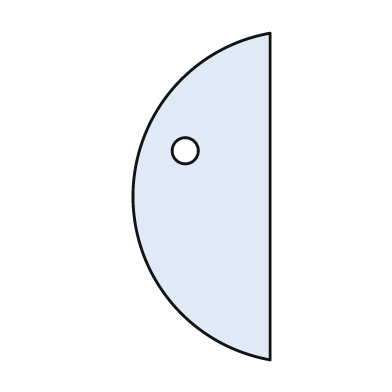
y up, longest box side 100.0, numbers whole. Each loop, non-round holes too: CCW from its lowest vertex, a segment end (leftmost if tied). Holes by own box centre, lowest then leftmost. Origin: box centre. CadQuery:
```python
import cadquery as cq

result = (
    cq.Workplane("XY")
    .moveTo(21.0, -50.0)
    .lineTo(21.0, 50.0)
    .threePointArc((-21.0, 0.0), (21.0, -50.0))
    .close()
    .moveTo(-5.0, 14.0)
    .circle(4.0)
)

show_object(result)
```